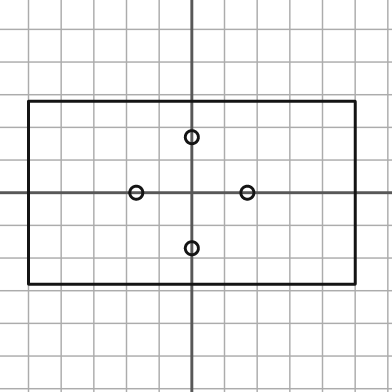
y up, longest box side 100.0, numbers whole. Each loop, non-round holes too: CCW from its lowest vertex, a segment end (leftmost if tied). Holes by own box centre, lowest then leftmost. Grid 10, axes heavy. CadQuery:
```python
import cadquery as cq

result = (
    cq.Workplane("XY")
    .moveTo(-50.0, -28.0)
    .lineTo(50.0, -28.0)
    .lineTo(50.0, 28.0)
    .lineTo(-50.0, 28.0)
    .close()
    .moveTo(0.0, -17.0)
    .circle(2.0)
    .moveTo(-17.0, 0.0)
    .circle(2.0)
    .moveTo(17.0, 0.0)
    .circle(2.0)
    .moveTo(0.0, 17.0)
    .circle(2.0)
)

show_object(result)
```